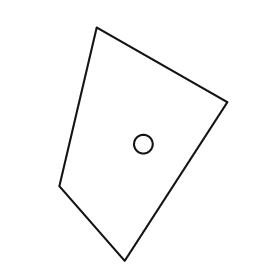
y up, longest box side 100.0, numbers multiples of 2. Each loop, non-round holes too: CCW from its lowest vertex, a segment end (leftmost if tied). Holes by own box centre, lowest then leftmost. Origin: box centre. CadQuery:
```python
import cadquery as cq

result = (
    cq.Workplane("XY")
    .moveTo(-8.0, -50.0)
    .lineTo(36.0, 18.0)
    .lineTo(-20.0, 50.0)
    .lineTo(-36.0, -18.0)
    .close()
    .moveTo(0.0, 0.0)
    .circle(4.0)
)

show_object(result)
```